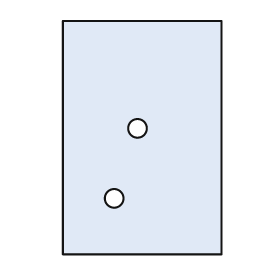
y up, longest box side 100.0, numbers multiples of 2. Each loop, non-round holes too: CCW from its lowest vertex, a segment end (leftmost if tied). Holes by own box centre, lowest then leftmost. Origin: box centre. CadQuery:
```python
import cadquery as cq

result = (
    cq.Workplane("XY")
    .moveTo(-34.0, -50.0)
    .lineTo(34.0, -50.0)
    .lineTo(34.0, 50.0)
    .lineTo(-34.0, 50.0)
    .close()
    .moveTo(-12.0, -26.0)
    .circle(4.0)
    .moveTo(-2.0, 4.0)
    .circle(4.0)
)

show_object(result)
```